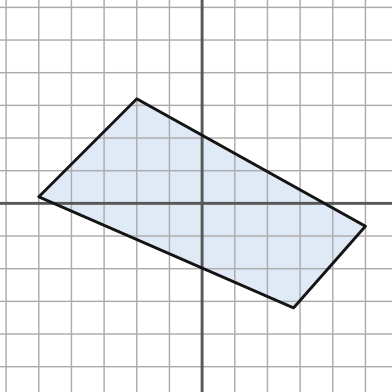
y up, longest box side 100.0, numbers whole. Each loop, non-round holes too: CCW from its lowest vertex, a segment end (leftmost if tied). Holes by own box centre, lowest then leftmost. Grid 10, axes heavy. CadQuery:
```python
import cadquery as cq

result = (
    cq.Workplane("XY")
    .moveTo(28.0, -32.0)
    .lineTo(50.0, -7.0)
    .lineTo(-20.0, 32.0)
    .lineTo(-50.0, 2.0)
    .close()
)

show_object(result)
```